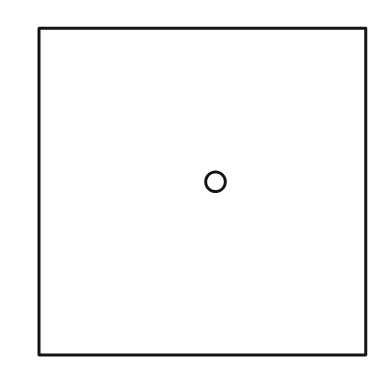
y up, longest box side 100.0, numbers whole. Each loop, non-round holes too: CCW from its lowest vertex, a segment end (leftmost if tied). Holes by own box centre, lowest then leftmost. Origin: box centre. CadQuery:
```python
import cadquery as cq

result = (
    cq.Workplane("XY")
    .moveTo(-50.0, -50.0)
    .lineTo(50.0, -50.0)
    .lineTo(50.0, 50.0)
    .lineTo(-50.0, 50.0)
    .close()
    .moveTo(4.0, 3.0)
    .circle(3.0)
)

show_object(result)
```